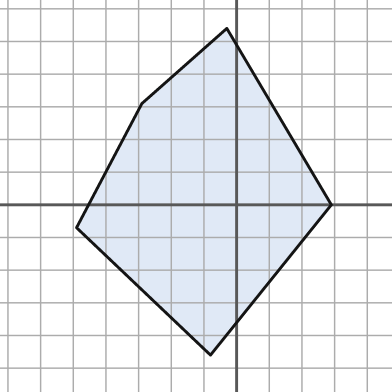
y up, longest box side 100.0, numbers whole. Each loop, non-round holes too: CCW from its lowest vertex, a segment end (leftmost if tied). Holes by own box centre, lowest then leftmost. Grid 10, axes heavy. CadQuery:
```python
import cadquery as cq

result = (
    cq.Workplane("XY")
    .moveTo(-8.0, -46.0)
    .lineTo(29.0, 0.0)
    .lineTo(-3.0, 54.0)
    .lineTo(-29.0, 31.0)
    .lineTo(-49.0, -7.0)
    .close()
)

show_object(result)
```